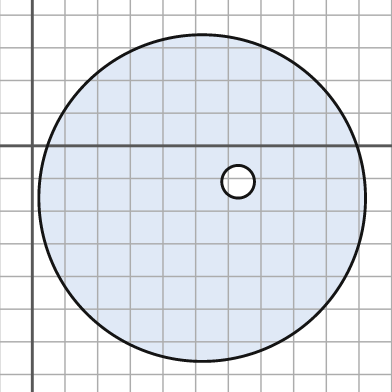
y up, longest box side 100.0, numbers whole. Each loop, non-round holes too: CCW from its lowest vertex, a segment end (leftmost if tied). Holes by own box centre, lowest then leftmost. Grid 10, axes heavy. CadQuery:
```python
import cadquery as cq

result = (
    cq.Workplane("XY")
    .moveTo(52.0, -16.0)
    .circle(50.0)
    .moveTo(63.0, -11.0)
    .circle(5.0)
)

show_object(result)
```